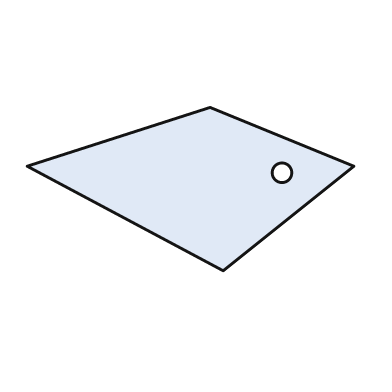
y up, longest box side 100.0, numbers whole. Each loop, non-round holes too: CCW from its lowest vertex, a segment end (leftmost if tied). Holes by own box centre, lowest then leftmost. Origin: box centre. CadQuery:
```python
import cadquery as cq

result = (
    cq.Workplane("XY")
    .moveTo(10.0, -25.0)
    .lineTo(50.0, 7.0)
    .lineTo(6.0, 25.0)
    .lineTo(-50.0, 7.0)
    .close()
    .moveTo(28.0, 5.0)
    .circle(3.0)
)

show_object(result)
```